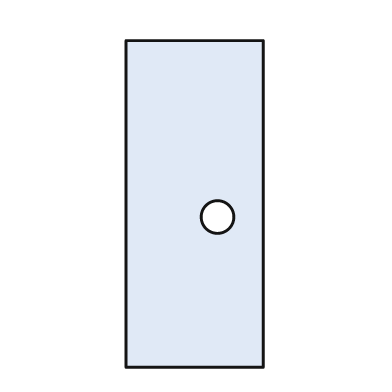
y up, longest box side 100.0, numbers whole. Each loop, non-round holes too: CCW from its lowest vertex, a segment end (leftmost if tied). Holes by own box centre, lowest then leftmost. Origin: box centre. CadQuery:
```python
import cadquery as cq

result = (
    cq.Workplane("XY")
    .moveTo(-21.0, -50.0)
    .lineTo(21.0, -50.0)
    .lineTo(21.0, 50.0)
    .lineTo(-21.0, 50.0)
    .close()
    .moveTo(7.0, -4.0)
    .circle(5.0)
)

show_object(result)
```